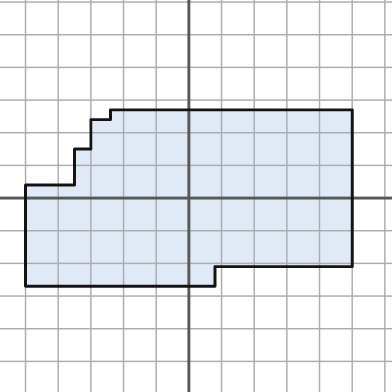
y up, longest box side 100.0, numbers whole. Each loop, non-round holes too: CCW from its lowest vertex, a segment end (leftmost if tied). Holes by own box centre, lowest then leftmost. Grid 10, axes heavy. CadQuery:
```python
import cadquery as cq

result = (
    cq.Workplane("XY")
    .moveTo(-50.0, -27.0)
    .lineTo(8.0, -27.0)
    .lineTo(8.0, -21.0)
    .lineTo(50.0, -21.0)
    .lineTo(50.0, 27.0)
    .lineTo(-24.0, 27.0)
    .lineTo(-24.0, 24.0)
    .lineTo(-30.0, 24.0)
    .lineTo(-30.0, 15.0)
    .lineTo(-35.0, 15.0)
    .lineTo(-35.0, 4.0)
    .lineTo(-50.0, 4.0)
    .close()
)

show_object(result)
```